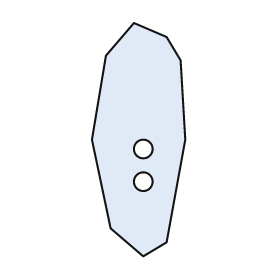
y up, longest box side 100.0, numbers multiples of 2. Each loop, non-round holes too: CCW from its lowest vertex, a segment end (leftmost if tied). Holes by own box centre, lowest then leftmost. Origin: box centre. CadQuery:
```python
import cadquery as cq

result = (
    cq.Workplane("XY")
    .moveTo(2.0, -50.0)
    .lineTo(12.0, -44.0)
    .lineTo(20.0, 0.0)
    .lineTo(18.0, 34.0)
    .lineTo(12.0, 44.0)
    .lineTo(-2.0, 50.0)
    .lineTo(-14.0, 36.0)
    .lineTo(-20.0, 0.0)
    .lineTo(-12.0, -38.0)
    .close()
    .moveTo(2.0, -18.0)
    .circle(4.0)
    .moveTo(2.0, -4.0)
    .circle(4.0)
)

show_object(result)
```